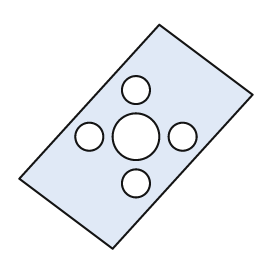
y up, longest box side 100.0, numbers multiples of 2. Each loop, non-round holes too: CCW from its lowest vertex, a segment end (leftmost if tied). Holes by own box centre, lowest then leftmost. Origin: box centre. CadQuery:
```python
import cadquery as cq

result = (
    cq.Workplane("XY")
    .moveTo(-10.0, -48.0)
    .lineTo(50.0, 18.0)
    .lineTo(10.0, 48.0)
    .lineTo(-50.0, -18.0)
    .close()
    .moveTo(0.0, -20.0)
    .circle(6.0)
    .moveTo(-20.0, 0.0)
    .circle(6.0)
    .moveTo(0.0, 0.0)
    .circle(10.0)
    .moveTo(20.0, 0.0)
    .circle(6.0)
    .moveTo(0.0, 20.0)
    .circle(6.0)
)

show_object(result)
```